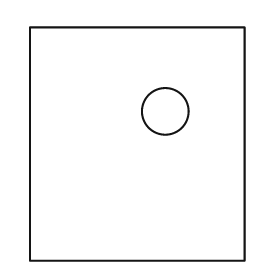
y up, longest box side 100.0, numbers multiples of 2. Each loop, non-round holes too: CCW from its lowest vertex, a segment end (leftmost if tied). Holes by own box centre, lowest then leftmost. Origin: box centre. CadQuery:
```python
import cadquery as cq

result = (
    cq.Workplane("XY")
    .moveTo(-46.0, -50.0)
    .lineTo(46.0, -50.0)
    .lineTo(46.0, 50.0)
    .lineTo(-46.0, 50.0)
    .close()
    .moveTo(12.0, 14.0)
    .circle(10.0)
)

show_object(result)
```